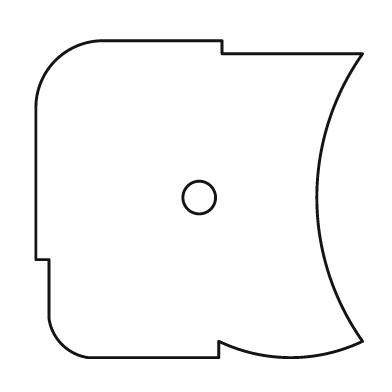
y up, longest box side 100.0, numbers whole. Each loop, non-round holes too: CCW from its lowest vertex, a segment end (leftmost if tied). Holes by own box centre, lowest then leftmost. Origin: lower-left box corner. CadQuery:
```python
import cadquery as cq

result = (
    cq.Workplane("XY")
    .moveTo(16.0, 0.0)
    .lineTo(56.0, 0.0)
    .lineTo(56.0, 5.0)
    .threePointArc((78.0, 0.0), (100.0, 5.0))
    .threePointArc((86.0, 49.0), (100.0, 93.0))
    .lineTo(57.0, 93.0)
    .lineTo(57.0, 97.0)
    .lineTo(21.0, 97.0)
    .threePointArc((6.0, 91.0), (0.0, 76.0))
    .lineTo(0.0, 30.0)
    .lineTo(4.0, 30.0)
    .lineTo(4.0, 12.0)
    .threePointArc((8.0, 4.0), (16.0, 0.0))
    .close()
    .moveTo(50.0, 49.0)
    .circle(5.0)
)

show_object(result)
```